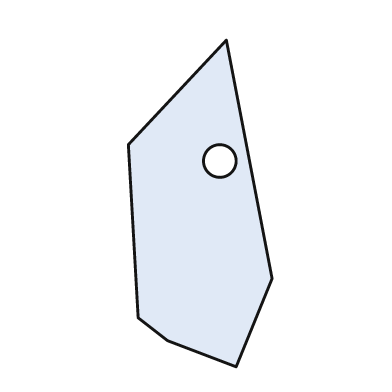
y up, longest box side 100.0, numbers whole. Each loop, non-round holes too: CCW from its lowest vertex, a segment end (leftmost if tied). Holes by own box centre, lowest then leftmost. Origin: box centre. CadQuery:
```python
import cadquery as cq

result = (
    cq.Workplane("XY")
    .moveTo(11.0, -50.0)
    .lineTo(22.0, -23.0)
    .lineTo(8.0, 50.0)
    .lineTo(-22.0, 18.0)
    .lineTo(-19.0, -35.0)
    .lineTo(-10.0, -42.0)
    .close()
    .moveTo(6.0, 13.0)
    .circle(5.0)
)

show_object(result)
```